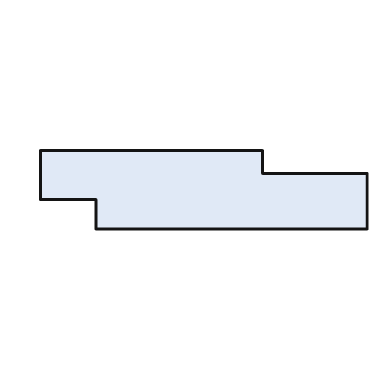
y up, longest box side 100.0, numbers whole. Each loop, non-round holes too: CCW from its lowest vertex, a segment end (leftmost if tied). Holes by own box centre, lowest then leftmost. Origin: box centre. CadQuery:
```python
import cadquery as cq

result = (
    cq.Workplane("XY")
    .moveTo(-33.0, -12.0)
    .lineTo(50.0, -12.0)
    .lineTo(50.0, 5.0)
    .lineTo(18.0, 5.0)
    .lineTo(18.0, 12.0)
    .lineTo(-50.0, 12.0)
    .lineTo(-50.0, -3.0)
    .lineTo(-33.0, -3.0)
    .close()
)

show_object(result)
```